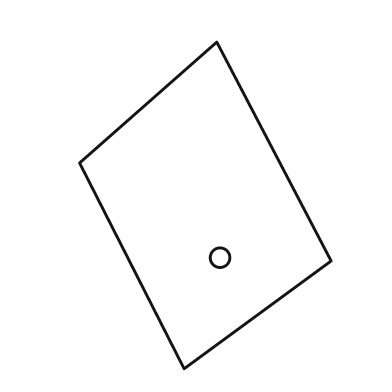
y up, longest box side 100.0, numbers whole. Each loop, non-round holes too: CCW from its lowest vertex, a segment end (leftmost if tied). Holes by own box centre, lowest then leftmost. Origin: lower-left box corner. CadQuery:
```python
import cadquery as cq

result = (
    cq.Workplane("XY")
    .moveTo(32.0, 0.0)
    .lineTo(77.0, 33.0)
    .lineTo(42.0, 100.0)
    .lineTo(0.0, 63.0)
    .close()
    .moveTo(43.0, 34.0)
    .circle(3.0)
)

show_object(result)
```